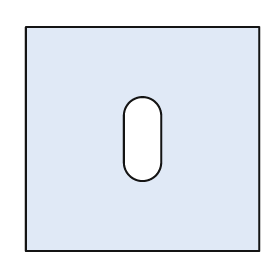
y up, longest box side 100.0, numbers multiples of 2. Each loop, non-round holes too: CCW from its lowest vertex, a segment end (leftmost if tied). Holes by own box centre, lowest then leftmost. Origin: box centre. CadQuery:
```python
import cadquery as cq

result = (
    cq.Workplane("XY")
    .moveTo(-50.0, -48.0)
    .lineTo(50.0, -48.0)
    .lineTo(50.0, 48.0)
    .lineTo(-50.0, 48.0)
    .close()
    .moveTo(-8.0, -10.0)
    .threePointArc((0.0, -18.0), (8.0, -10.0))
    .lineTo(8.0, 10.0)
    .threePointArc((0.0, 18.0), (-8.0, 10.0))
    .close()
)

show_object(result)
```